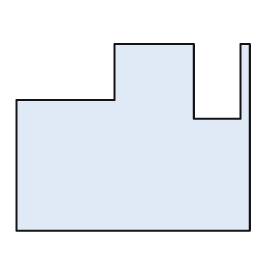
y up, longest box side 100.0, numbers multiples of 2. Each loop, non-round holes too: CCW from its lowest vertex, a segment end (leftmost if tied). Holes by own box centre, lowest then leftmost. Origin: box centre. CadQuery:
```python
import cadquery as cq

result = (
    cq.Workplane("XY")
    .moveTo(-50.0, -40.0)
    .lineTo(50.0, -40.0)
    .lineTo(50.0, 40.0)
    .lineTo(46.0, 40.0)
    .lineTo(46.0, 8.0)
    .lineTo(26.0, 8.0)
    .lineTo(26.0, 40.0)
    .lineTo(-8.0, 40.0)
    .lineTo(-8.0, 16.0)
    .lineTo(-50.0, 16.0)
    .close()
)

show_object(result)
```